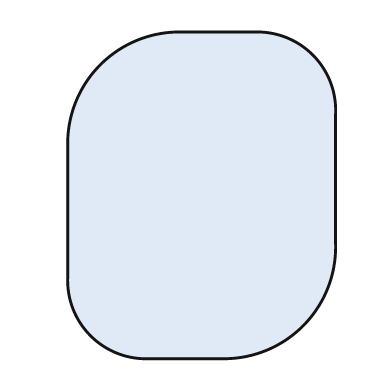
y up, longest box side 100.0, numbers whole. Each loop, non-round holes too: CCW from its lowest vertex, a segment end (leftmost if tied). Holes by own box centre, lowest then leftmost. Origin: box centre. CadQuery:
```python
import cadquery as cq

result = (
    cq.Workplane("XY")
    .moveTo(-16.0, -50.0)
    .lineTo(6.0, -50.0)
    .threePointArc((31.0, -40.0), (41.0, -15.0))
    .lineTo(41.0, 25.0)
    .threePointArc((34.0, 43.0), (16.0, 50.0))
    .lineTo(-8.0, 50.0)
    .threePointArc((-31.0, 40.0), (-41.0, 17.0))
    .lineTo(-41.0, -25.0)
    .threePointArc((-34.0, -43.0), (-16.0, -50.0))
    .close()
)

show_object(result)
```